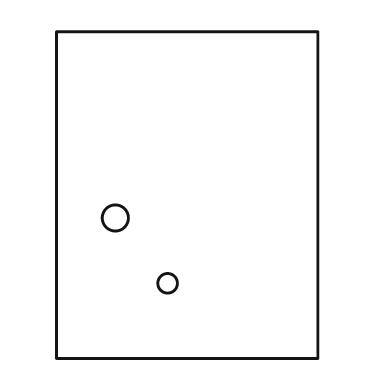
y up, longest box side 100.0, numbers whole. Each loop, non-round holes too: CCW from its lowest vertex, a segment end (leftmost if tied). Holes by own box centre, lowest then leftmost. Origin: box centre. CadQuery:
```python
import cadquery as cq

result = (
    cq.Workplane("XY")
    .moveTo(-40.0, -50.0)
    .lineTo(40.0, -50.0)
    .lineTo(40.0, 50.0)
    .lineTo(-40.0, 50.0)
    .close()
    .moveTo(-6.0, -27.0)
    .circle(3.0)
    .moveTo(-22.0, -7.0)
    .circle(4.0)
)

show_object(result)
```